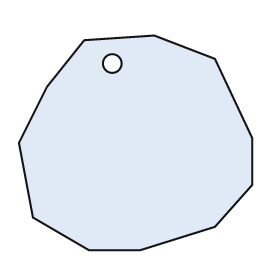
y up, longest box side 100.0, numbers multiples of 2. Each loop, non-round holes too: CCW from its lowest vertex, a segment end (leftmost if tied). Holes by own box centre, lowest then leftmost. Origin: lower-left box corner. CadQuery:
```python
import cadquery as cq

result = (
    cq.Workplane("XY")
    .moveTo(30.0, 0.0)
    .lineTo(52.0, 0.0)
    .lineTo(84.0, 10.0)
    .lineTo(100.0, 28.0)
    .lineTo(100.0, 48.0)
    .lineTo(84.0, 82.0)
    .lineTo(58.0, 92.0)
    .lineTo(28.0, 90.0)
    .lineTo(12.0, 70.0)
    .lineTo(0.0, 46.0)
    .lineTo(6.0, 14.0)
    .close()
    .moveTo(40.0, 80.0)
    .circle(4.0)
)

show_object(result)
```